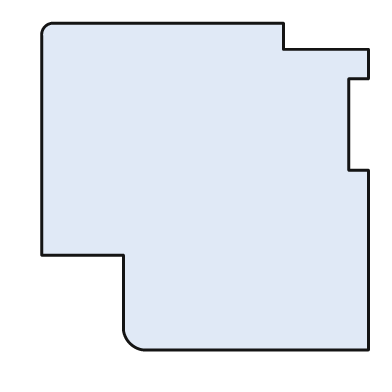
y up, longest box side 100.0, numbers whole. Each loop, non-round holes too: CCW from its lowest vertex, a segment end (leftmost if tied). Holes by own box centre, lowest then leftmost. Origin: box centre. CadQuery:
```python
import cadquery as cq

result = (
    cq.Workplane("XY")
    .moveTo(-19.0, -50.0)
    .lineTo(50.0, -50.0)
    .lineTo(50.0, 5.0)
    .lineTo(44.0, 5.0)
    .lineTo(44.0, 33.0)
    .lineTo(50.0, 33.0)
    .lineTo(50.0, 42.0)
    .lineTo(24.0, 42.0)
    .lineTo(24.0, 50.0)
    .lineTo(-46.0, 50.0)
    .threePointArc((-49.0, 49.0), (-50.0, 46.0))
    .lineTo(-50.0, -21.0)
    .lineTo(-25.0, -21.0)
    .lineTo(-25.0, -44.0)
    .threePointArc((-23.0, -48.0), (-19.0, -50.0))
    .close()
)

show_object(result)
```